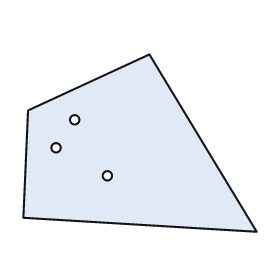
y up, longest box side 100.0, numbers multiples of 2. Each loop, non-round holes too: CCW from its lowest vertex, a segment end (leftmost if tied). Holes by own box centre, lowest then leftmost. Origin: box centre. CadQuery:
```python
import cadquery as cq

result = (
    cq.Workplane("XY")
    .moveTo(50.0, -38.0)
    .lineTo(4.0, 38.0)
    .lineTo(-48.0, 14.0)
    .lineTo(-50.0, -32.0)
    .close()
    .moveTo(-14.0, -14.0)
    .circle(2.0)
    .moveTo(-36.0, -2.0)
    .circle(2.0)
    .moveTo(-28.0, 10.0)
    .circle(2.0)
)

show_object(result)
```